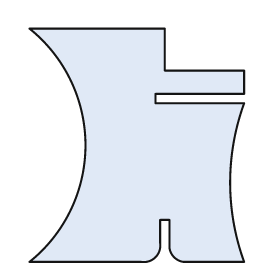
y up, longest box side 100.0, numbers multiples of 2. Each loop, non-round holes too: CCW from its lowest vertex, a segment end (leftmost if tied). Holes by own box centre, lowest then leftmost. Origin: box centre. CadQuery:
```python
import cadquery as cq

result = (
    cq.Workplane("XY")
    .moveTo(-46.0, -50.0)
    .lineTo(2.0, -50.0)
    .threePointArc((8.0, -48.0), (10.0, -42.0))
    .lineTo(10.0, -32.0)
    .lineTo(14.0, -32.0)
    .lineTo(14.0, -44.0)
    .threePointArc((16.0, -48.0), (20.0, -50.0))
    .lineTo(46.0, -50.0)
    .threePointArc((40.0, -16.0), (46.0, 18.0))
    .lineTo(8.0, 18.0)
    .lineTo(8.0, 22.0)
    .lineTo(46.0, 22.0)
    .lineTo(46.0, 32.0)
    .lineTo(12.0, 32.0)
    .lineTo(12.0, 50.0)
    .lineTo(-46.0, 50.0)
    .threePointArc((-22.0, 0.0), (-46.0, -50.0))
    .close()
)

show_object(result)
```